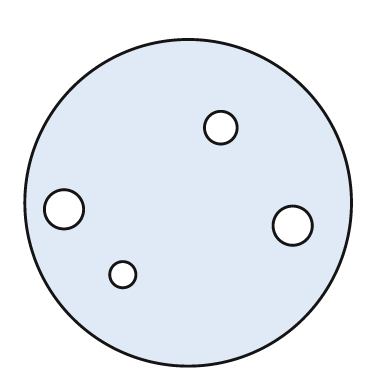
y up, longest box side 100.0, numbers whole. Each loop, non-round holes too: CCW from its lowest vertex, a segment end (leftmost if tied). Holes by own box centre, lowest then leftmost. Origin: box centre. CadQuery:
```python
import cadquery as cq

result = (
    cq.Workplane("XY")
    .moveTo(0.0, 0.0)
    .circle(50.0)
    .moveTo(-20.0, -22.0)
    .circle(4.0)
    .moveTo(32.0, -7.0)
    .circle(6.0)
    .moveTo(-38.0, -2.0)
    .circle(6.0)
    .moveTo(10.0, 23.0)
    .circle(5.0)
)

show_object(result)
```